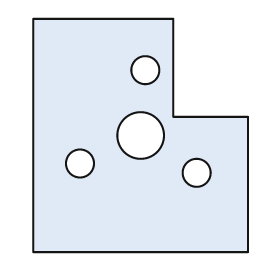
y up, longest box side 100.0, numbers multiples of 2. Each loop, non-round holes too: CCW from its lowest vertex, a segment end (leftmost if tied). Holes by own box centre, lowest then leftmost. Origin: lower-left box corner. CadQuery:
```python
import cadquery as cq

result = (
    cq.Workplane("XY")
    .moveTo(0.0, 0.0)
    .lineTo(92.0, 0.0)
    .lineTo(92.0, 58.0)
    .lineTo(60.0, 58.0)
    .lineTo(60.0, 100.0)
    .lineTo(0.0, 100.0)
    .close()
    .moveTo(70.0, 34.0)
    .circle(6.0)
    .moveTo(20.0, 38.0)
    .circle(6.0)
    .moveTo(46.0, 50.0)
    .circle(10.0)
    .moveTo(48.0, 78.0)
    .circle(6.0)
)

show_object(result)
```